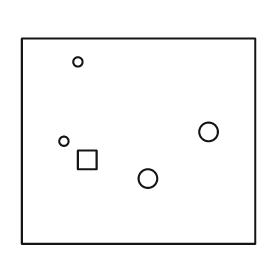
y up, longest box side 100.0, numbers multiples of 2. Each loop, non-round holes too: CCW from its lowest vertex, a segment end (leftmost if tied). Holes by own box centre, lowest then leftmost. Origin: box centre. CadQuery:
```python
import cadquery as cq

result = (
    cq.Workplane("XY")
    .moveTo(-50.0, -44.0)
    .lineTo(50.0, -44.0)
    .lineTo(50.0, 44.0)
    .lineTo(-50.0, 44.0)
    .close()
    .moveTo(4.0, -16.0)
    .circle(4.0)
    .moveTo(-26.0, -12.0)
    .lineTo(-18.0, -12.0)
    .lineTo(-18.0, -4.0)
    .lineTo(-26.0, -4.0)
    .close()
    .moveTo(-32.0, 0.0)
    .circle(2.0)
    .moveTo(30.0, 4.0)
    .circle(4.0)
    .moveTo(-26.0, 34.0)
    .circle(2.0)
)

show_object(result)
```